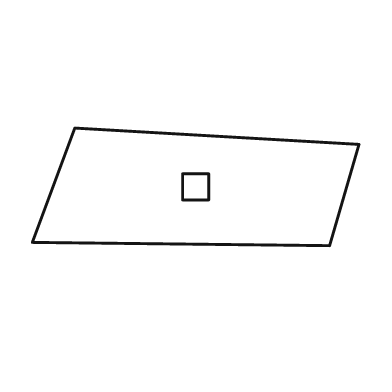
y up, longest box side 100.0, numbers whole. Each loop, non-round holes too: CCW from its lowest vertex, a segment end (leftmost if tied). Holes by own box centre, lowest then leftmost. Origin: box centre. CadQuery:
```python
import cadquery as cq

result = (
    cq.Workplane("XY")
    .moveTo(41.0, -18.0)
    .lineTo(50.0, 13.0)
    .lineTo(-37.0, 18.0)
    .lineTo(-50.0, -17.0)
    .close()
    .moveTo(-4.0, -4.0)
    .lineTo(4.0, -4.0)
    .lineTo(4.0, 4.0)
    .lineTo(-4.0, 4.0)
    .close()
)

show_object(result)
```